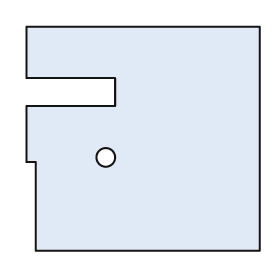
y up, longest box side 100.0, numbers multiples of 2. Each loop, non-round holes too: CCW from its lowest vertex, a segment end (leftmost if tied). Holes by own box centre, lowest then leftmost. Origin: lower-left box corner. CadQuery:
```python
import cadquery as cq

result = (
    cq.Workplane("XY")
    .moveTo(4.0, 0.0)
    .lineTo(100.0, 0.0)
    .lineTo(100.0, 96.0)
    .lineTo(0.0, 96.0)
    .lineTo(0.0, 74.0)
    .lineTo(38.0, 74.0)
    .lineTo(38.0, 62.0)
    .lineTo(0.0, 62.0)
    .lineTo(0.0, 38.0)
    .lineTo(4.0, 38.0)
    .close()
    .moveTo(34.0, 40.0)
    .circle(4.0)
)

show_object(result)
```